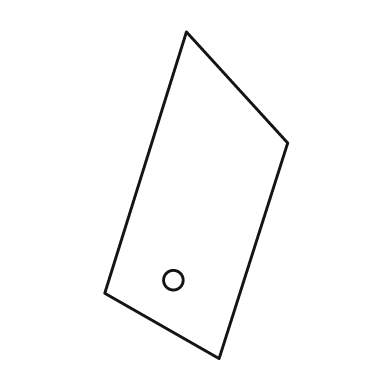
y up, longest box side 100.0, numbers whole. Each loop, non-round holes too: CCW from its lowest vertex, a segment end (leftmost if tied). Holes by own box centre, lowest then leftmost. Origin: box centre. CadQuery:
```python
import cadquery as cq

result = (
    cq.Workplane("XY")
    .moveTo(7.0, -50.0)
    .lineTo(28.0, 16.0)
    .lineTo(-3.0, 50.0)
    .lineTo(-28.0, -30.0)
    .close()
    .moveTo(-7.0, -26.0)
    .circle(3.0)
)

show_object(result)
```